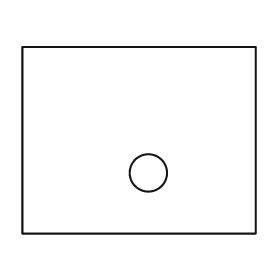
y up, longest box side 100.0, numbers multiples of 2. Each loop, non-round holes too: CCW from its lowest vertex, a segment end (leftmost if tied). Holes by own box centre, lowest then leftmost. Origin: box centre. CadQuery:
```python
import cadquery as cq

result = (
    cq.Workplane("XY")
    .moveTo(-50.0, -40.0)
    .lineTo(50.0, -40.0)
    .lineTo(50.0, 40.0)
    .lineTo(-50.0, 40.0)
    .close()
    .moveTo(4.0, -14.0)
    .circle(8.0)
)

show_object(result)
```